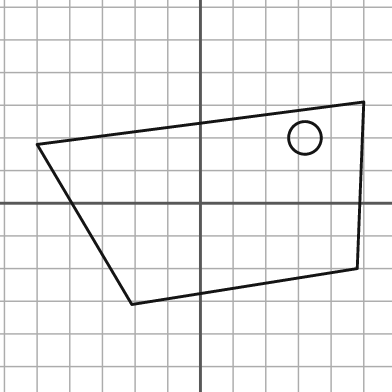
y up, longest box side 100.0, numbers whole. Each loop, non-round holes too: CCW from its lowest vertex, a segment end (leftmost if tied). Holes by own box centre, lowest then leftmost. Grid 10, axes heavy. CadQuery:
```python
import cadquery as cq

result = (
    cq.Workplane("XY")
    .moveTo(-21.0, -31.0)
    .lineTo(48.0, -20.0)
    .lineTo(50.0, 31.0)
    .lineTo(-50.0, 18.0)
    .close()
    .moveTo(32.0, 20.0)
    .circle(5.0)
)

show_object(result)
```